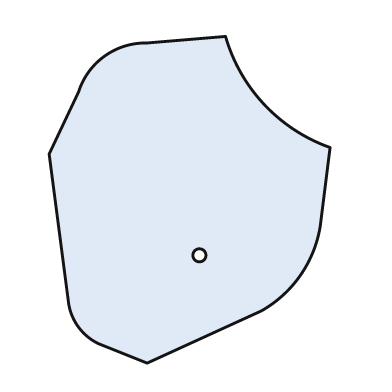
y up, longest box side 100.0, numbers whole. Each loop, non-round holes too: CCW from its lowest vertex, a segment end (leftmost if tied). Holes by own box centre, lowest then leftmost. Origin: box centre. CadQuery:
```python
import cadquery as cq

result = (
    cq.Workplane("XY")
    .moveTo(-13.0, -50.0)
    .lineTo(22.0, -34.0)
    .threePointArc((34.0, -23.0), (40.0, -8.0))
    .lineTo(43.0, 16.0)
    .threePointArc((23.0, 29.0), (11.0, 50.0))
    .lineTo(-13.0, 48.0)
    .threePointArc((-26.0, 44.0), (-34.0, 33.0))
    .lineTo(-43.0, 14.0)
    .lineTo(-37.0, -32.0)
    .threePointArc((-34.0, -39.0), (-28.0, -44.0))
    .close()
    .moveTo(3.0, -17.0)
    .circle(2.0)
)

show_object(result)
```